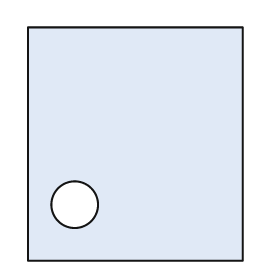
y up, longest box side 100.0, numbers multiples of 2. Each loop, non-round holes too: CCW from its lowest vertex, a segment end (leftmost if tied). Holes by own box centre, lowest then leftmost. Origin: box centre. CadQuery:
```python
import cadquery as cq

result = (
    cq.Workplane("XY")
    .moveTo(-46.0, -50.0)
    .lineTo(46.0, -50.0)
    .lineTo(46.0, 50.0)
    .lineTo(-46.0, 50.0)
    .close()
    .moveTo(-26.0, -26.0)
    .circle(10.0)
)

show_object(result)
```